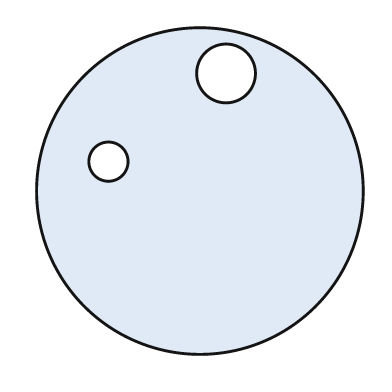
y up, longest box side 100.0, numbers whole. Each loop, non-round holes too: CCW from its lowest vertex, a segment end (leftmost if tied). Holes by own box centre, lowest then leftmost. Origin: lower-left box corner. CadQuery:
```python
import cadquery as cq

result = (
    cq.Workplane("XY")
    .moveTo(50.0, 50.0)
    .circle(50.0)
    .moveTo(22.0, 59.0)
    .circle(6.0)
    .moveTo(58.0, 86.0)
    .circle(9.0)
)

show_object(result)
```